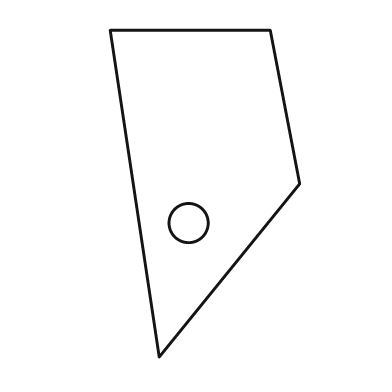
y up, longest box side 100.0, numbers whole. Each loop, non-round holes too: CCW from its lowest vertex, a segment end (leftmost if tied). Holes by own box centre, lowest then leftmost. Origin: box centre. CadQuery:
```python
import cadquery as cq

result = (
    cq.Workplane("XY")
    .moveTo(-14.0, -50.0)
    .lineTo(29.0, 3.0)
    .lineTo(20.0, 50.0)
    .lineTo(-29.0, 50.0)
    .close()
    .moveTo(-5.0, -9.0)
    .circle(6.0)
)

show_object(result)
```